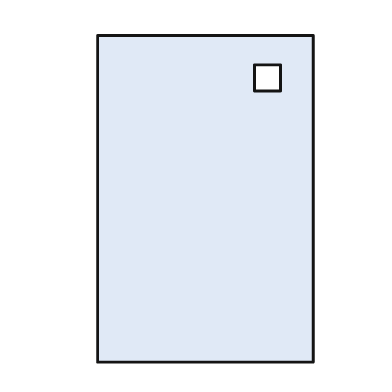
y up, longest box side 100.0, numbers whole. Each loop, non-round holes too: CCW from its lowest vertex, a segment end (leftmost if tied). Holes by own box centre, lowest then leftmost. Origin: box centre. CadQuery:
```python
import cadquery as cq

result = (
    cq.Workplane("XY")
    .moveTo(-33.0, -50.0)
    .lineTo(33.0, -50.0)
    .lineTo(33.0, 50.0)
    .lineTo(-33.0, 50.0)
    .close()
    .moveTo(15.0, 33.0)
    .lineTo(23.0, 33.0)
    .lineTo(23.0, 41.0)
    .lineTo(15.0, 41.0)
    .close()
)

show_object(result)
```